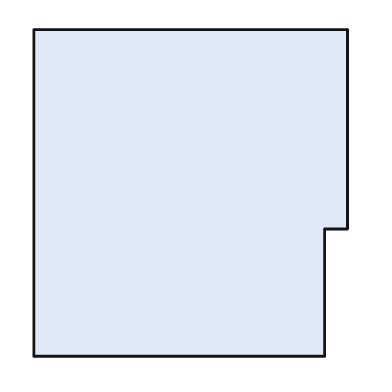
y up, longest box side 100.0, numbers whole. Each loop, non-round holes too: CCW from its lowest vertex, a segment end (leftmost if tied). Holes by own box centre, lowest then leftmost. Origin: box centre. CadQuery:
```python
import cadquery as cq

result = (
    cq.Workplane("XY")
    .moveTo(-48.0, -50.0)
    .lineTo(41.0, -50.0)
    .lineTo(41.0, -11.0)
    .lineTo(48.0, -11.0)
    .lineTo(48.0, 50.0)
    .lineTo(-48.0, 50.0)
    .close()
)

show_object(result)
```